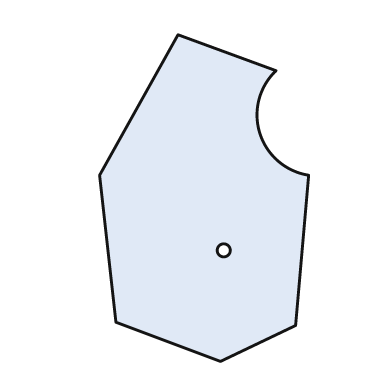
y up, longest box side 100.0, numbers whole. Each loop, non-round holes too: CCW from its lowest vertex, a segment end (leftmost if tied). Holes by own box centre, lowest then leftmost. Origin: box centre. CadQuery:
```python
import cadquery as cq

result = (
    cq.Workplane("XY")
    .moveTo(5.0, -50.0)
    .lineTo(28.0, -39.0)
    .lineTo(32.0, 7.0)
    .threePointArc((17.0, 20.0), (22.0, 39.0))
    .lineTo(-8.0, 50.0)
    .lineTo(-32.0, 7.0)
    .lineTo(-27.0, -38.0)
    .close()
    .moveTo(6.0, -16.0)
    .circle(2.0)
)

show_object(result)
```